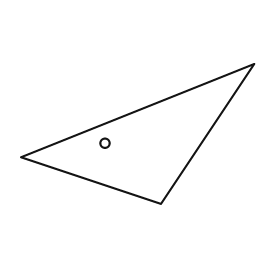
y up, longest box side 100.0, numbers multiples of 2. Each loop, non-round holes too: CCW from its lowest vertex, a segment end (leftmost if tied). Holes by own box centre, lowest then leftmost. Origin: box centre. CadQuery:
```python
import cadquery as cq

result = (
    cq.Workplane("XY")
    .moveTo(10.0, -30.0)
    .lineTo(50.0, 30.0)
    .lineTo(-50.0, -10.0)
    .close()
    .moveTo(-14.0, -4.0)
    .circle(2.0)
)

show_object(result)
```